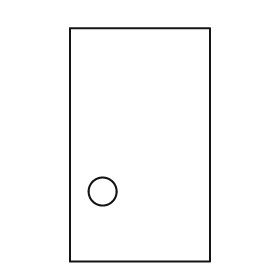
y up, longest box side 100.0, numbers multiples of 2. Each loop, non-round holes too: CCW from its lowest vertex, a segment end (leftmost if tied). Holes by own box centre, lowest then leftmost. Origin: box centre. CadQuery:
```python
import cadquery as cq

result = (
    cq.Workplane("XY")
    .moveTo(-30.0, -50.0)
    .lineTo(30.0, -50.0)
    .lineTo(30.0, 50.0)
    .lineTo(-30.0, 50.0)
    .close()
    .moveTo(-16.0, -20.0)
    .circle(6.0)
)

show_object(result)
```